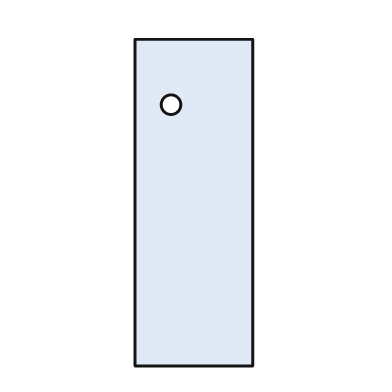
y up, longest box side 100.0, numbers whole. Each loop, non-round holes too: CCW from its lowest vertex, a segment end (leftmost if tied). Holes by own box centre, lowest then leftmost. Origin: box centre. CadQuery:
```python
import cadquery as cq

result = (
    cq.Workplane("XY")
    .moveTo(-18.0, -50.0)
    .lineTo(18.0, -50.0)
    .lineTo(18.0, 50.0)
    .lineTo(-18.0, 50.0)
    .close()
    .moveTo(-7.0, 30.0)
    .circle(3.0)
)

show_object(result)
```